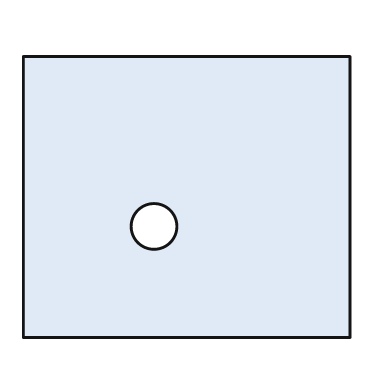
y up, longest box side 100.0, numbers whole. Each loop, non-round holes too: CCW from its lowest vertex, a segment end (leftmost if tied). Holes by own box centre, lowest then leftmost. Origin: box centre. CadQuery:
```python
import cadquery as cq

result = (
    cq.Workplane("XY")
    .moveTo(-50.0, -43.0)
    .lineTo(50.0, -43.0)
    .lineTo(50.0, 43.0)
    .lineTo(-50.0, 43.0)
    .close()
    .moveTo(-10.0, -9.0)
    .circle(7.0)
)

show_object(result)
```